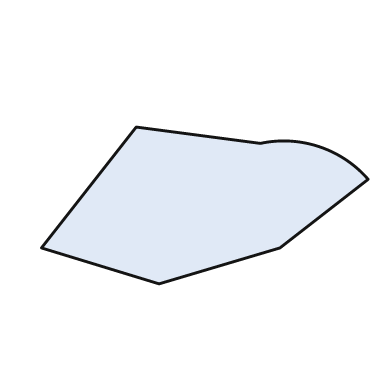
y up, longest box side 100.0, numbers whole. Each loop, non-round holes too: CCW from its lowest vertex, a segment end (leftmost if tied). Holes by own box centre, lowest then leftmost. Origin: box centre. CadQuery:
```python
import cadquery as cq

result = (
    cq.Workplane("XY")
    .moveTo(-14.0, -24.0)
    .lineTo(23.0, -13.0)
    .lineTo(50.0, 8.0)
    .threePointArc((35.0, 18.0), (17.0, 19.0))
    .lineTo(-21.0, 24.0)
    .lineTo(-50.0, -13.0)
    .close()
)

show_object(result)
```